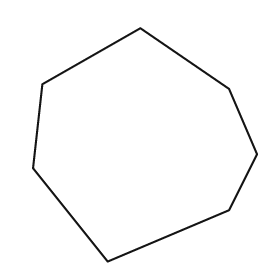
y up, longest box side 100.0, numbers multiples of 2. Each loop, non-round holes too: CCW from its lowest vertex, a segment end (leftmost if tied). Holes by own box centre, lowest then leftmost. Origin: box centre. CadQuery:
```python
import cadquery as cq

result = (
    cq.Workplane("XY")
    .moveTo(-16.0, -50.0)
    .lineTo(36.0, -28.0)
    .lineTo(48.0, -4.0)
    .lineTo(36.0, 24.0)
    .lineTo(-2.0, 50.0)
    .lineTo(-44.0, 26.0)
    .lineTo(-48.0, -10.0)
    .close()
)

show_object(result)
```